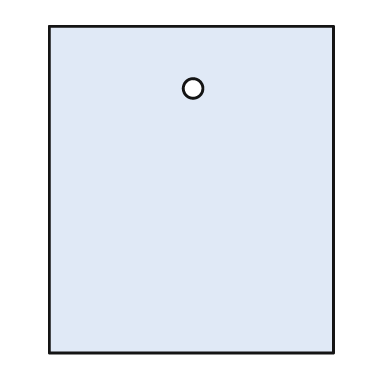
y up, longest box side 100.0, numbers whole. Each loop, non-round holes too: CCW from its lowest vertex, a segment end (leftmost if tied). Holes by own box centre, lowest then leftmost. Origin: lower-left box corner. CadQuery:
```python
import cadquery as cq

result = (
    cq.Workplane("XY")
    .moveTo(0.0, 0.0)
    .lineTo(87.0, 0.0)
    .lineTo(87.0, 100.0)
    .lineTo(0.0, 100.0)
    .close()
    .moveTo(44.0, 81.0)
    .circle(3.0)
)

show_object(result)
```